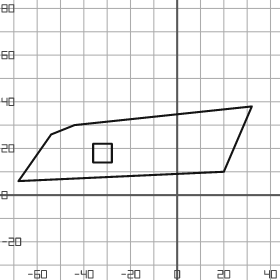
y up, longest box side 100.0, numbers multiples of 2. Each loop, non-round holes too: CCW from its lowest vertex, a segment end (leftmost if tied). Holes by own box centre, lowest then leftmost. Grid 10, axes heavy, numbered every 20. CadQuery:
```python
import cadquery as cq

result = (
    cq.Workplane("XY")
    .moveTo(-68.0, 6.0)
    .lineTo(20.0, 10.0)
    .lineTo(32.0, 38.0)
    .lineTo(-44.0, 30.0)
    .lineTo(-54.0, 26.0)
    .close()
    .moveTo(-36.0, 14.0)
    .lineTo(-28.0, 14.0)
    .lineTo(-28.0, 22.0)
    .lineTo(-36.0, 22.0)
    .close()
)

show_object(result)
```